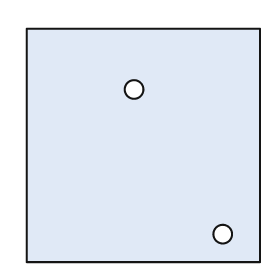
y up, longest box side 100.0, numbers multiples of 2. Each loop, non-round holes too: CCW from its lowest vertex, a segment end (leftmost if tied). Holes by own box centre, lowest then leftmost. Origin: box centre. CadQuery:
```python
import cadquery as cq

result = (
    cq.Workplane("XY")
    .moveTo(-50.0, -50.0)
    .lineTo(50.0, -50.0)
    .lineTo(50.0, 50.0)
    .lineTo(-50.0, 50.0)
    .close()
    .moveTo(34.0, -38.0)
    .circle(4.0)
    .moveTo(-4.0, 24.0)
    .circle(4.0)
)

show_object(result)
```